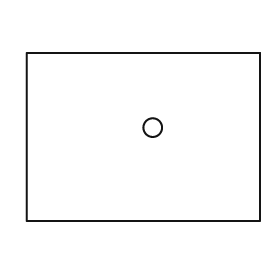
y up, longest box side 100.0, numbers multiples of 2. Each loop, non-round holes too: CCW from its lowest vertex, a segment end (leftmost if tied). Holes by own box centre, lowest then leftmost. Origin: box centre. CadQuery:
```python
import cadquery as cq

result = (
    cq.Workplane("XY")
    .moveTo(-50.0, -36.0)
    .lineTo(50.0, -36.0)
    .lineTo(50.0, 36.0)
    .lineTo(-50.0, 36.0)
    .close()
    .moveTo(4.0, 4.0)
    .circle(4.0)
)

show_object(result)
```